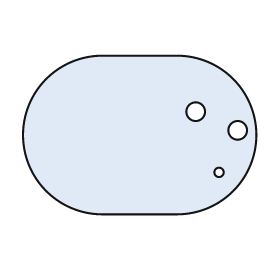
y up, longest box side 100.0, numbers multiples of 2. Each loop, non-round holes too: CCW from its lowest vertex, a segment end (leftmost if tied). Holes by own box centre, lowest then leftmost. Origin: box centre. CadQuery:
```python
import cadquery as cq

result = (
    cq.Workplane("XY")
    .moveTo(-16.0, -34.0)
    .lineTo(16.0, -34.0)
    .threePointArc((50.0, 0.0), (16.0, 34.0))
    .lineTo(-16.0, 34.0)
    .threePointArc((-50.0, 0.0), (-16.0, -34.0))
    .close()
    .moveTo(34.0, -16.0)
    .circle(2.0)
    .moveTo(42.0, 2.0)
    .circle(4.0)
    .moveTo(24.0, 10.0)
    .circle(4.0)
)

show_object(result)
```